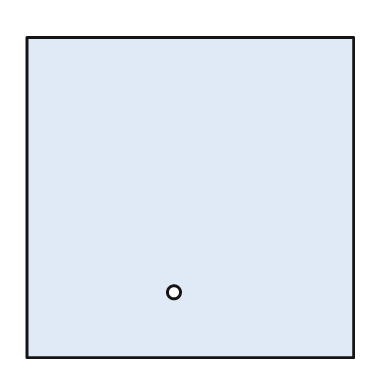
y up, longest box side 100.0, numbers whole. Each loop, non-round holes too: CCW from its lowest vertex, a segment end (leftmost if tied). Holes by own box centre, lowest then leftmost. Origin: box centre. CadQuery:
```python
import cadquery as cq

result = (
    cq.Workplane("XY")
    .moveTo(-50.0, -49.0)
    .lineTo(50.0, -49.0)
    .lineTo(50.0, 49.0)
    .lineTo(-50.0, 49.0)
    .close()
    .moveTo(-5.0, -29.0)
    .circle(2.0)
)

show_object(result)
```